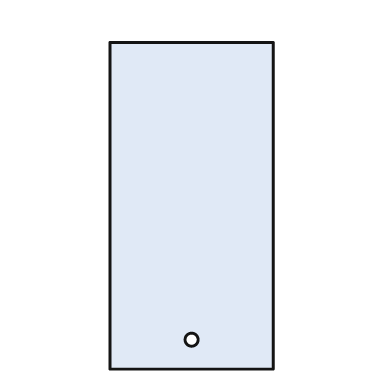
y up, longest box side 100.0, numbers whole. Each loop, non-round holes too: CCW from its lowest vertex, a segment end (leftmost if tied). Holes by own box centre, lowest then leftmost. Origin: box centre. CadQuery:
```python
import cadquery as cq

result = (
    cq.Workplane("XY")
    .moveTo(-25.0, -50.0)
    .lineTo(25.0, -50.0)
    .lineTo(25.0, 50.0)
    .lineTo(-25.0, 50.0)
    .close()
    .moveTo(0.0, -41.0)
    .circle(2.0)
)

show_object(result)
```